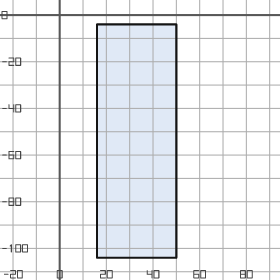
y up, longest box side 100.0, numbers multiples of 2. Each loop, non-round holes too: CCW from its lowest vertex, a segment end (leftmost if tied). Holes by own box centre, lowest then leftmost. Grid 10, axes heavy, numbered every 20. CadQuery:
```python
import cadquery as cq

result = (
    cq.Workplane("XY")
    .moveTo(16.0, -104.0)
    .lineTo(50.0, -104.0)
    .lineTo(50.0, -4.0)
    .lineTo(16.0, -4.0)
    .close()
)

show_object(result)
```